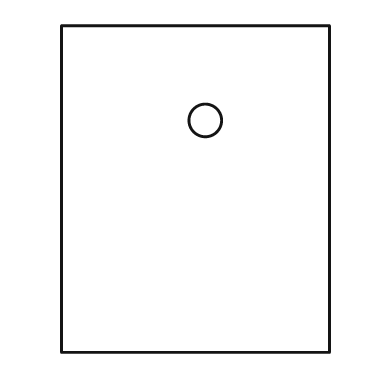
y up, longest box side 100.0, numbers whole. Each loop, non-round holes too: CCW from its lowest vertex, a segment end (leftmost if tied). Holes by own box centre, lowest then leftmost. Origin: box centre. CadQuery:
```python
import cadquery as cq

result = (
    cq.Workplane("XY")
    .moveTo(-41.0, -50.0)
    .lineTo(41.0, -50.0)
    .lineTo(41.0, 50.0)
    .lineTo(-41.0, 50.0)
    .close()
    .moveTo(3.0, 21.0)
    .circle(5.0)
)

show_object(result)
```